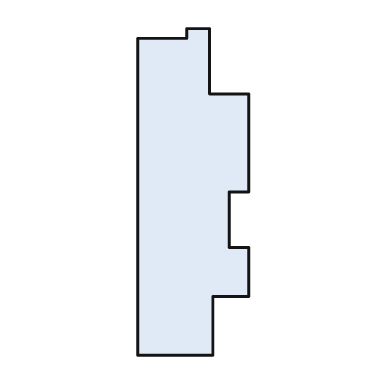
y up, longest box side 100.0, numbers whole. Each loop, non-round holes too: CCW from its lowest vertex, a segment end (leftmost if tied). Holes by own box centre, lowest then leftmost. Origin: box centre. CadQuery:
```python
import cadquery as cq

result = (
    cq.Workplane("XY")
    .moveTo(-17.0, -50.0)
    .lineTo(6.0, -50.0)
    .lineTo(6.0, -32.0)
    .lineTo(17.0, -32.0)
    .lineTo(17.0, -17.0)
    .lineTo(11.0, -17.0)
    .lineTo(11.0, 0.0)
    .lineTo(17.0, 0.0)
    .lineTo(17.0, 30.0)
    .lineTo(5.0, 30.0)
    .lineTo(5.0, 50.0)
    .lineTo(-2.0, 50.0)
    .lineTo(-2.0, 47.0)
    .lineTo(-17.0, 47.0)
    .close()
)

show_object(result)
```